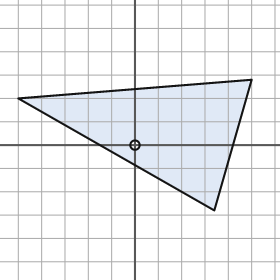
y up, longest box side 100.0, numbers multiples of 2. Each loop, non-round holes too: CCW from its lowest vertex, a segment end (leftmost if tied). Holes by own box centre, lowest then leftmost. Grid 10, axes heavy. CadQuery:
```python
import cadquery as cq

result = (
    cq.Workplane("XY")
    .moveTo(34.0, -28.0)
    .lineTo(50.0, 28.0)
    .lineTo(-50.0, 20.0)
    .close()
    .moveTo(0.0, 0.0)
    .circle(2.0)
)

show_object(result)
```